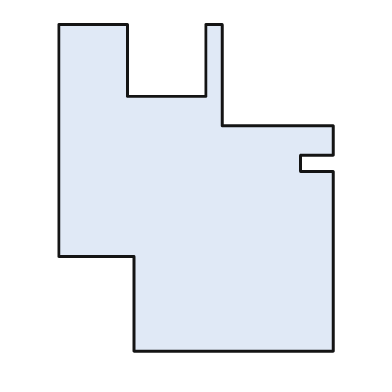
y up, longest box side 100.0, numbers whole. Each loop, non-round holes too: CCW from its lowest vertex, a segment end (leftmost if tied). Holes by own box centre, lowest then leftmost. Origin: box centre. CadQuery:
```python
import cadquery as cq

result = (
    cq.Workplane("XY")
    .moveTo(-19.0, -50.0)
    .lineTo(42.0, -50.0)
    .lineTo(42.0, 5.0)
    .lineTo(32.0, 5.0)
    .lineTo(32.0, 10.0)
    .lineTo(42.0, 10.0)
    .lineTo(42.0, 19.0)
    .lineTo(8.0, 19.0)
    .lineTo(8.0, 50.0)
    .lineTo(3.0, 50.0)
    .lineTo(3.0, 28.0)
    .lineTo(-21.0, 28.0)
    .lineTo(-21.0, 50.0)
    .lineTo(-42.0, 50.0)
    .lineTo(-42.0, -21.0)
    .lineTo(-19.0, -21.0)
    .close()
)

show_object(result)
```